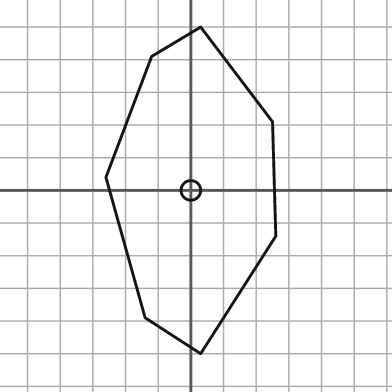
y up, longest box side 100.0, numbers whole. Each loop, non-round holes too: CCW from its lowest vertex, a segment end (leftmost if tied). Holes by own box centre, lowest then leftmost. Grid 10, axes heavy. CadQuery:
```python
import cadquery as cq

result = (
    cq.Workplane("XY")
    .moveTo(3.0, -50.0)
    .lineTo(26.0, -14.0)
    .lineTo(25.0, 21.0)
    .lineTo(3.0, 50.0)
    .lineTo(-12.0, 41.0)
    .lineTo(-26.0, 4.0)
    .lineTo(-14.0, -39.0)
    .close()
    .moveTo(0.0, 0.0)
    .circle(3.0)
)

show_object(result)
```